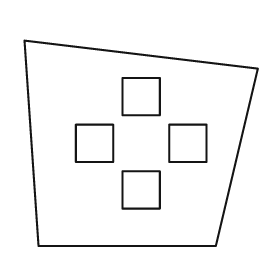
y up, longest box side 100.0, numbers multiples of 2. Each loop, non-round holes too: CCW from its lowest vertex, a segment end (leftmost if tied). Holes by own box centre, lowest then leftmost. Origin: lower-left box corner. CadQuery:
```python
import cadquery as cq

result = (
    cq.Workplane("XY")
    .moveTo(6.0, 0.0)
    .lineTo(82.0, 0.0)
    .lineTo(100.0, 76.0)
    .lineTo(0.0, 88.0)
    .close()
    .moveTo(42.0, 16.0)
    .lineTo(58.0, 16.0)
    .lineTo(58.0, 32.0)
    .lineTo(42.0, 32.0)
    .close()
    .moveTo(22.0, 36.0)
    .lineTo(38.0, 36.0)
    .lineTo(38.0, 52.0)
    .lineTo(22.0, 52.0)
    .close()
    .moveTo(62.0, 36.0)
    .lineTo(78.0, 36.0)
    .lineTo(78.0, 52.0)
    .lineTo(62.0, 52.0)
    .close()
    .moveTo(42.0, 56.0)
    .lineTo(58.0, 56.0)
    .lineTo(58.0, 72.0)
    .lineTo(42.0, 72.0)
    .close()
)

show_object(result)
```